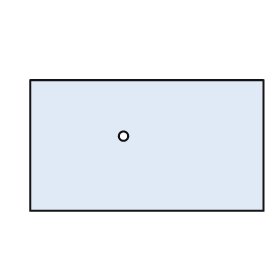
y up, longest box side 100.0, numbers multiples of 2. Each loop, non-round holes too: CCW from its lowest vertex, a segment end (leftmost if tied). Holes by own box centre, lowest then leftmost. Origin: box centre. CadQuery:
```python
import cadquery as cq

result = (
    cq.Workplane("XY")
    .moveTo(-50.0, -28.0)
    .lineTo(50.0, -28.0)
    .lineTo(50.0, 28.0)
    .lineTo(-50.0, 28.0)
    .close()
    .moveTo(-10.0, 4.0)
    .circle(2.0)
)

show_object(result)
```